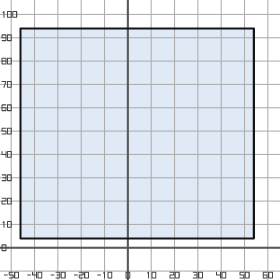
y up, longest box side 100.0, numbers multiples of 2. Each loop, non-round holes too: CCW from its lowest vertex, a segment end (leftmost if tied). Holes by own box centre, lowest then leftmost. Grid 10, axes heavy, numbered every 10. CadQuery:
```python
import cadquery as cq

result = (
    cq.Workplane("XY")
    .moveTo(-46.0, 4.0)
    .lineTo(54.0, 4.0)
    .lineTo(54.0, 94.0)
    .lineTo(-46.0, 94.0)
    .close()
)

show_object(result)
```